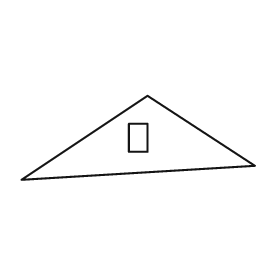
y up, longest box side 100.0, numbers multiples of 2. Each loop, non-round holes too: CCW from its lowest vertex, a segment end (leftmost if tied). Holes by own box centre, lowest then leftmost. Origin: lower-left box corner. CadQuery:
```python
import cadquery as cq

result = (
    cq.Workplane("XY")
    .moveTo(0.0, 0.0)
    .lineTo(100.0, 6.0)
    .lineTo(54.0, 36.0)
    .close()
    .moveTo(46.0, 12.0)
    .lineTo(54.0, 12.0)
    .lineTo(54.0, 24.0)
    .lineTo(46.0, 24.0)
    .close()
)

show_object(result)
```